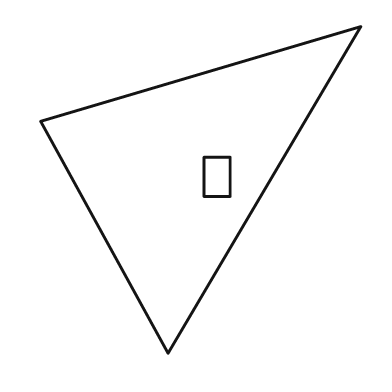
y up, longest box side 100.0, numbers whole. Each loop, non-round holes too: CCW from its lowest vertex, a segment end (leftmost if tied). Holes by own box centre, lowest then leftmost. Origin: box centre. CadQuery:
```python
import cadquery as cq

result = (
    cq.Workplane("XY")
    .moveTo(-10.0, -50.0)
    .lineTo(49.0, 50.0)
    .lineTo(-49.0, 21.0)
    .close()
    .moveTo(1.0, -2.0)
    .lineTo(9.0, -2.0)
    .lineTo(9.0, 10.0)
    .lineTo(1.0, 10.0)
    .close()
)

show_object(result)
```